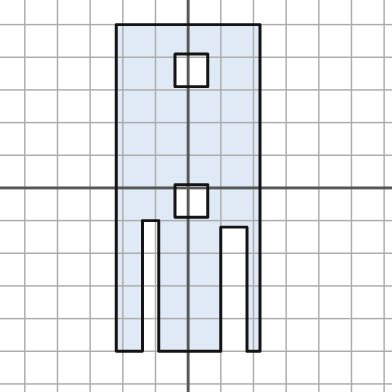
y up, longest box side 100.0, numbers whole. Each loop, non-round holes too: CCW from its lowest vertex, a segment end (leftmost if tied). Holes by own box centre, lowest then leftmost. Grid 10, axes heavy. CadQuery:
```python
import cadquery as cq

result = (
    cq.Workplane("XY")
    .moveTo(-22.0, -50.0)
    .lineTo(-14.0, -50.0)
    .lineTo(-14.0, -10.0)
    .lineTo(-9.0, -10.0)
    .lineTo(-9.0, -50.0)
    .lineTo(10.0, -50.0)
    .lineTo(10.0, -12.0)
    .lineTo(18.0, -12.0)
    .lineTo(18.0, -50.0)
    .lineTo(22.0, -50.0)
    .lineTo(22.0, 50.0)
    .lineTo(-22.0, 50.0)
    .close()
    .moveTo(-4.0, -9.0)
    .lineTo(6.0, -9.0)
    .lineTo(6.0, 1.0)
    .lineTo(-4.0, 1.0)
    .close()
    .moveTo(-4.0, 31.0)
    .lineTo(6.0, 31.0)
    .lineTo(6.0, 41.0)
    .lineTo(-4.0, 41.0)
    .close()
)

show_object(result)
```